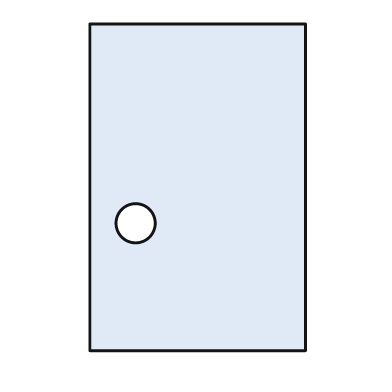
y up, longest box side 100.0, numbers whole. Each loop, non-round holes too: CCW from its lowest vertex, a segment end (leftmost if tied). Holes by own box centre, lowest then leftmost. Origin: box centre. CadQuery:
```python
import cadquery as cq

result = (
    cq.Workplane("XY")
    .moveTo(-33.0, -50.0)
    .lineTo(33.0, -50.0)
    .lineTo(33.0, 50.0)
    .lineTo(-33.0, 50.0)
    .close()
    .moveTo(-19.0, -11.0)
    .circle(6.0)
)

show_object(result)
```